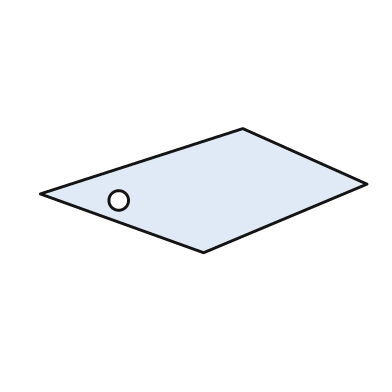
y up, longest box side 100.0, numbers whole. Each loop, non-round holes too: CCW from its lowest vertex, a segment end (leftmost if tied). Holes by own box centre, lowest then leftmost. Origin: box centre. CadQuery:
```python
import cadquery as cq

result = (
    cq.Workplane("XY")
    .moveTo(0.0, -19.0)
    .lineTo(50.0, 2.0)
    .lineTo(12.0, 19.0)
    .lineTo(-50.0, -1.0)
    .close()
    .moveTo(-26.0, -3.0)
    .circle(3.0)
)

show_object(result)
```